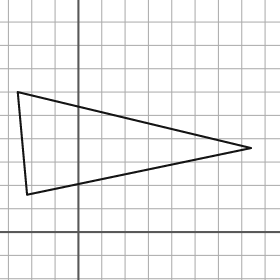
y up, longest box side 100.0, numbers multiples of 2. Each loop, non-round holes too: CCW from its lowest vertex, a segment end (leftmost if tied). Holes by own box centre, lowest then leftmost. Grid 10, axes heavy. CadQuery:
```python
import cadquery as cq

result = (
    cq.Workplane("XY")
    .moveTo(-22.0, 16.0)
    .lineTo(74.0, 36.0)
    .lineTo(-26.0, 60.0)
    .close()
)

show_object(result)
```